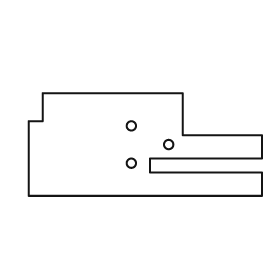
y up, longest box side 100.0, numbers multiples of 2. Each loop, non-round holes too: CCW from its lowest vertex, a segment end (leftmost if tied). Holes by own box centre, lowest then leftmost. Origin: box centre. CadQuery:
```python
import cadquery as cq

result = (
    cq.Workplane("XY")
    .moveTo(-50.0, -22.0)
    .lineTo(50.0, -22.0)
    .lineTo(50.0, -12.0)
    .lineTo(2.0, -12.0)
    .lineTo(2.0, -6.0)
    .lineTo(50.0, -6.0)
    .lineTo(50.0, 4.0)
    .lineTo(16.0, 4.0)
    .lineTo(16.0, 22.0)
    .lineTo(-44.0, 22.0)
    .lineTo(-44.0, 10.0)
    .lineTo(-50.0, 10.0)
    .close()
    .moveTo(-6.0, -8.0)
    .circle(2.0)
    .moveTo(10.0, 0.0)
    .circle(2.0)
    .moveTo(-6.0, 8.0)
    .circle(2.0)
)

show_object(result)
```